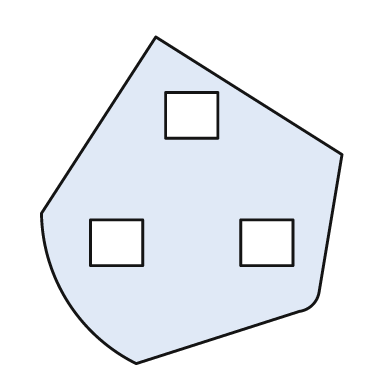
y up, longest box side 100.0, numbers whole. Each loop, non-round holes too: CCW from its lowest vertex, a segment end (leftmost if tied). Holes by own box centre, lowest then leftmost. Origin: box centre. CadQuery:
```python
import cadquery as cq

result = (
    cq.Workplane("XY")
    .moveTo(-17.0, -50.0)
    .lineTo(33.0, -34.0)
    .threePointArc((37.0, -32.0), (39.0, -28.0))
    .lineTo(46.0, 14.0)
    .lineTo(-11.0, 50.0)
    .lineTo(-46.0, -4.0)
    .threePointArc((-38.0, -31.0), (-17.0, -50.0))
    .close()
    .moveTo(-31.0, -20.0)
    .lineTo(-15.0, -20.0)
    .lineTo(-15.0, -6.0)
    .lineTo(-31.0, -6.0)
    .close()
    .moveTo(15.0, -20.0)
    .lineTo(31.0, -20.0)
    .lineTo(31.0, -6.0)
    .lineTo(15.0, -6.0)
    .close()
    .moveTo(-8.0, 19.0)
    .lineTo(8.0, 19.0)
    .lineTo(8.0, 33.0)
    .lineTo(-8.0, 33.0)
    .close()
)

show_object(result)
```